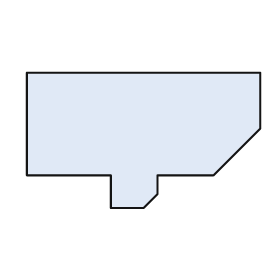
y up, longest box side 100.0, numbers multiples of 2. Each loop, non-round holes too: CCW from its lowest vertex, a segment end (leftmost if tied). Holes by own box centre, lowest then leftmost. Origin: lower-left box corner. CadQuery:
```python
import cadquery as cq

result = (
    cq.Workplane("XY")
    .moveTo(36.0, 0.0)
    .lineTo(50.0, 0.0)
    .lineTo(56.0, 6.0)
    .lineTo(56.0, 14.0)
    .lineTo(80.0, 14.0)
    .lineTo(100.0, 34.0)
    .lineTo(100.0, 58.0)
    .lineTo(0.0, 58.0)
    .lineTo(0.0, 14.0)
    .lineTo(36.0, 14.0)
    .close()
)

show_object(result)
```